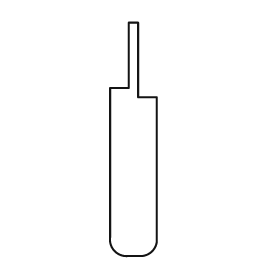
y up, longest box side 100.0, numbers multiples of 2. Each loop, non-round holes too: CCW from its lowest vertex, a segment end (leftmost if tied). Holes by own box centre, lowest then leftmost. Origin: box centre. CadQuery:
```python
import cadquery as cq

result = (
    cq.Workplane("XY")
    .moveTo(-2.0, -50.0)
    .lineTo(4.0, -50.0)
    .threePointArc((8.0, -48.0), (10.0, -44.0))
    .lineTo(10.0, 18.0)
    .lineTo(2.0, 18.0)
    .lineTo(2.0, 50.0)
    .lineTo(-2.0, 50.0)
    .lineTo(-2.0, 22.0)
    .lineTo(-10.0, 22.0)
    .lineTo(-10.0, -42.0)
    .threePointArc((-8.0, -48.0), (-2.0, -50.0))
    .close()
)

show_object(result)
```